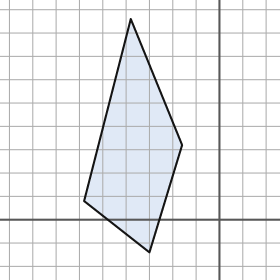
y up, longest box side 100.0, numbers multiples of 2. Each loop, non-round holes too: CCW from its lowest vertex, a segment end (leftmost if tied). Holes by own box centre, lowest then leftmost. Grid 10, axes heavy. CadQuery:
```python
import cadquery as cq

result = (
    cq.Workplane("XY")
    .moveTo(-30.0, -14.0)
    .lineTo(-16.0, 32.0)
    .lineTo(-38.0, 86.0)
    .lineTo(-58.0, 8.0)
    .close()
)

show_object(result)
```